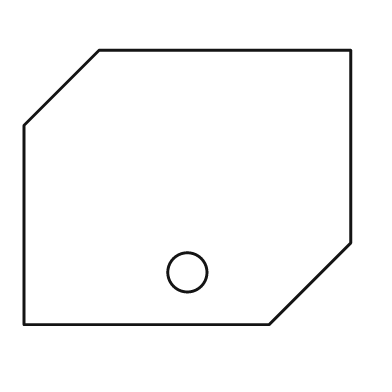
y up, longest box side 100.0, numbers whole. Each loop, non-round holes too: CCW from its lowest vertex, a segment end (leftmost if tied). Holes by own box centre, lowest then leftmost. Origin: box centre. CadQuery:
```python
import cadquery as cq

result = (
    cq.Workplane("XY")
    .moveTo(-50.0, -42.0)
    .lineTo(25.0, -42.0)
    .lineTo(50.0, -17.0)
    .lineTo(50.0, 42.0)
    .lineTo(-27.0, 42.0)
    .lineTo(-50.0, 19.0)
    .close()
    .moveTo(0.0, -26.0)
    .circle(6.0)
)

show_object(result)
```